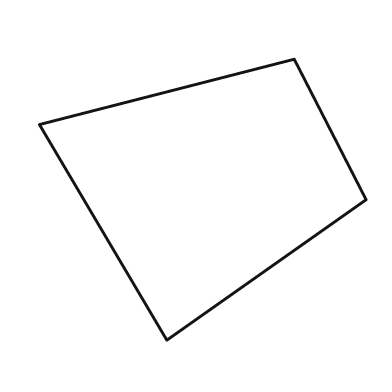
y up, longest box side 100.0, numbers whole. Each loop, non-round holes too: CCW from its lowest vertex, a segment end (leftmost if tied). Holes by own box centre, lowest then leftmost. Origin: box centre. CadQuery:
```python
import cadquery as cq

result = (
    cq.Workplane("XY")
    .moveTo(-11.0, -43.0)
    .lineTo(50.0, 0.0)
    .lineTo(28.0, 43.0)
    .lineTo(-50.0, 23.0)
    .close()
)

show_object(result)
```